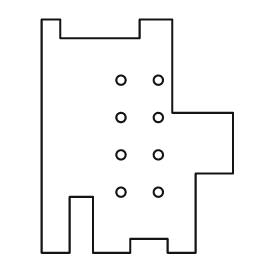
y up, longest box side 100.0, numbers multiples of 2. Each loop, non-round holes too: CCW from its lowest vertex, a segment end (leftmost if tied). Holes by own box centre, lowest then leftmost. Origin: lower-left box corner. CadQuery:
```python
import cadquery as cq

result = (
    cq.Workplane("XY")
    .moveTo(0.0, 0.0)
    .lineTo(12.0, 0.0)
    .lineTo(12.0, 24.0)
    .lineTo(22.0, 24.0)
    .lineTo(22.0, 0.0)
    .lineTo(38.0, 0.0)
    .lineTo(38.0, 6.0)
    .lineTo(54.0, 6.0)
    .lineTo(54.0, 0.0)
    .lineTo(66.0, 0.0)
    .lineTo(66.0, 34.0)
    .lineTo(82.0, 34.0)
    .lineTo(82.0, 60.0)
    .lineTo(56.0, 60.0)
    .lineTo(56.0, 100.0)
    .lineTo(42.0, 100.0)
    .lineTo(42.0, 92.0)
    .lineTo(8.0, 92.0)
    .lineTo(8.0, 100.0)
    .lineTo(0.0, 100.0)
    .close()
    .moveTo(34.0, 26.0)
    .circle(2.0)
    .moveTo(50.0, 26.0)
    .circle(2.0)
    .moveTo(34.0, 42.0)
    .circle(2.0)
    .moveTo(50.0, 42.0)
    .circle(2.0)
    .moveTo(34.0, 58.0)
    .circle(2.0)
    .moveTo(50.0, 58.0)
    .circle(2.0)
    .moveTo(34.0, 74.0)
    .circle(2.0)
    .moveTo(50.0, 74.0)
    .circle(2.0)
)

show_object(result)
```